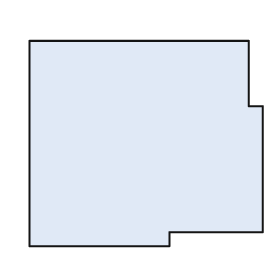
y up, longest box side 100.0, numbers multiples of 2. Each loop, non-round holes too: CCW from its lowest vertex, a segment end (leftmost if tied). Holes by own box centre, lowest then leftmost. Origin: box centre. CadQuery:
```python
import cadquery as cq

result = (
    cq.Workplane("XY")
    .moveTo(-50.0, -44.0)
    .lineTo(10.0, -44.0)
    .lineTo(10.0, -38.0)
    .lineTo(50.0, -38.0)
    .lineTo(50.0, 16.0)
    .lineTo(44.0, 16.0)
    .lineTo(44.0, 44.0)
    .lineTo(-50.0, 44.0)
    .close()
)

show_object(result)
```